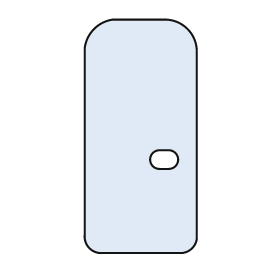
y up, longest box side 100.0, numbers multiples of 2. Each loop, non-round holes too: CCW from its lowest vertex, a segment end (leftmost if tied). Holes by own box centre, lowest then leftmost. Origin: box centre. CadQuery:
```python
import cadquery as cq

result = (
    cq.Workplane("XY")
    .moveTo(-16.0, -50.0)
    .lineTo(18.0, -50.0)
    .threePointArc((22.0, -48.0), (24.0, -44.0))
    .lineTo(24.0, 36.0)
    .threePointArc((20.0, 46.0), (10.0, 50.0))
    .lineTo(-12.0, 50.0)
    .threePointArc((-20.0, 46.0), (-24.0, 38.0))
    .lineTo(-24.0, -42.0)
    .threePointArc((-22.0, -48.0), (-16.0, -50.0))
    .close()
    .moveTo(8.0, -14.0)
    .lineTo(12.0, -14.0)
    .threePointArc((16.0, -10.0), (12.0, -6.0))
    .lineTo(8.0, -6.0)
    .threePointArc((4.0, -10.0), (8.0, -14.0))
    .close()
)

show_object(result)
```